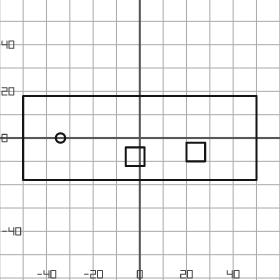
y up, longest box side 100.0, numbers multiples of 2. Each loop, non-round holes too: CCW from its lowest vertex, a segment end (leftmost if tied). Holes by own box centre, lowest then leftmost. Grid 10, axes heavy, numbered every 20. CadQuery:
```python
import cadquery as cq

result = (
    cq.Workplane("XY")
    .moveTo(-50.0, -18.0)
    .lineTo(50.0, -18.0)
    .lineTo(50.0, 18.0)
    .lineTo(-50.0, 18.0)
    .close()
    .moveTo(-6.0, -12.0)
    .lineTo(2.0, -12.0)
    .lineTo(2.0, -4.0)
    .lineTo(-6.0, -4.0)
    .close()
    .moveTo(20.0, -10.0)
    .lineTo(28.0, -10.0)
    .lineTo(28.0, -2.0)
    .lineTo(20.0, -2.0)
    .close()
    .moveTo(-34.0, 0.0)
    .circle(2.0)
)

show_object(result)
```